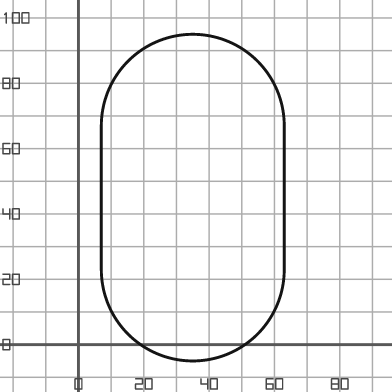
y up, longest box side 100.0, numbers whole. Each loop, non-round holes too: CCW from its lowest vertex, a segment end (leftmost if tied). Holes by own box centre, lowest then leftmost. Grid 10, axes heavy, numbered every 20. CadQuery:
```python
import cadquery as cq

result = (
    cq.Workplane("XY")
    .moveTo(7.0, 23.0)
    .threePointArc((35.0, -5.0), (63.0, 23.0))
    .lineTo(63.0, 67.0)
    .threePointArc((35.0, 95.0), (7.0, 67.0))
    .close()
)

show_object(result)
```